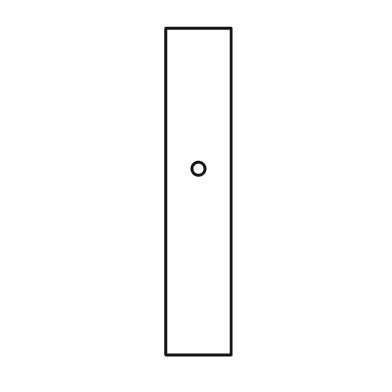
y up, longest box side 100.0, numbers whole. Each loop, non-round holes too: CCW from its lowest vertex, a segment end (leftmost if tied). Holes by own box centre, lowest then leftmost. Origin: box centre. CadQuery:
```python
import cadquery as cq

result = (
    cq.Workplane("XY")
    .moveTo(-10.0, -50.0)
    .lineTo(10.0, -50.0)
    .lineTo(10.0, 50.0)
    .lineTo(-10.0, 50.0)
    .close()
    .moveTo(0.0, 7.0)
    .circle(2.0)
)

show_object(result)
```